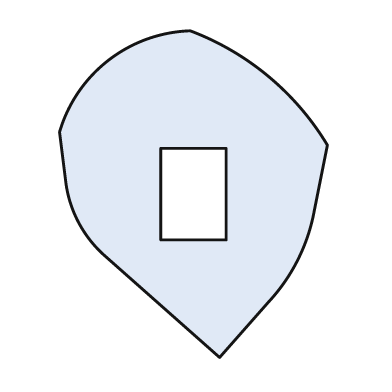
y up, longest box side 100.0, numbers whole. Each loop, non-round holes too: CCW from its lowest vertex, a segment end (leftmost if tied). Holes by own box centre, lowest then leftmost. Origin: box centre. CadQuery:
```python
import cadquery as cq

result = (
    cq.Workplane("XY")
    .moveTo(8.0, -50.0)
    .lineTo(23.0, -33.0)
    .threePointArc((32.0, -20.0), (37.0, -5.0))
    .lineTo(41.0, 15.0)
    .threePointArc((23.0, 36.0), (-1.0, 50.0))
    .threePointArc((-26.0, 41.0), (-41.0, 19.0))
    .lineTo(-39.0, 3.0)
    .threePointArc((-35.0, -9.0), (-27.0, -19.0))
    .close()
    .moveTo(-10.0, -14.0)
    .lineTo(10.0, -14.0)
    .lineTo(10.0, 14.0)
    .lineTo(-10.0, 14.0)
    .close()
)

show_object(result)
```